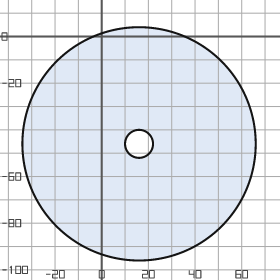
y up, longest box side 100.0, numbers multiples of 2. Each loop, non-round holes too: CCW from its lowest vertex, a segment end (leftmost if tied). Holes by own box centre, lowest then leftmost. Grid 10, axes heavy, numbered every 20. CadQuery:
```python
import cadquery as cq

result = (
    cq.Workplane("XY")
    .moveTo(16.0, -46.0)
    .circle(50.0)
    .moveTo(16.0, -46.0)
    .circle(6.0)
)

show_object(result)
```